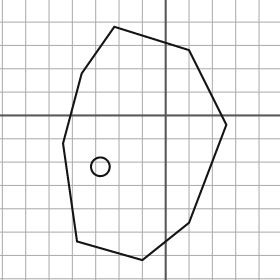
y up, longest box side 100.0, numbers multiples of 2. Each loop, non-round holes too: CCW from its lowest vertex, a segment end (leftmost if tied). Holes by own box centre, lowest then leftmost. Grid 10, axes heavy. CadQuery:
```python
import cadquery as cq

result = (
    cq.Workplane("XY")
    .moveTo(-10.0, -62.0)
    .lineTo(10.0, -46.0)
    .lineTo(26.0, -4.0)
    .lineTo(10.0, 28.0)
    .lineTo(-22.0, 38.0)
    .lineTo(-36.0, 18.0)
    .lineTo(-44.0, -12.0)
    .lineTo(-38.0, -54.0)
    .close()
    .moveTo(-28.0, -22.0)
    .circle(4.0)
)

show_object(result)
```